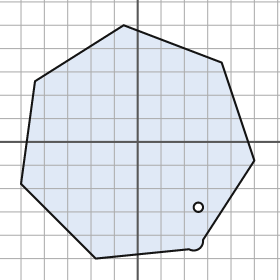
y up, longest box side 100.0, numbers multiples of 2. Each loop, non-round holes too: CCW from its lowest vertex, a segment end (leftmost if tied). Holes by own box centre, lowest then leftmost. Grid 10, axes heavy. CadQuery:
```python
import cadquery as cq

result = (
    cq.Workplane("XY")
    .moveTo(-18.0, -50.0)
    .lineTo(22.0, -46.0)
    .threePointArc((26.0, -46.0), (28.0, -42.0))
    .lineTo(50.0, -8.0)
    .lineTo(36.0, 34.0)
    .lineTo(-6.0, 50.0)
    .lineTo(-44.0, 26.0)
    .lineTo(-50.0, -18.0)
    .close()
    .moveTo(26.0, -28.0)
    .circle(2.0)
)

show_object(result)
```